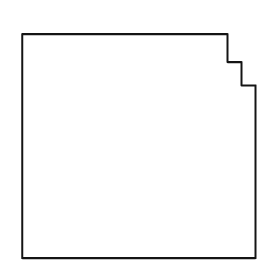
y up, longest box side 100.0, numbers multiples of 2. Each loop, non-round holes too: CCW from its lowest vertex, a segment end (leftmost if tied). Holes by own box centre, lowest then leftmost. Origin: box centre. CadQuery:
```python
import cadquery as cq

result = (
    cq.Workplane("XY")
    .moveTo(-50.0, -48.0)
    .lineTo(50.0, -48.0)
    .lineTo(50.0, 26.0)
    .lineTo(44.0, 26.0)
    .lineTo(44.0, 36.0)
    .lineTo(38.0, 36.0)
    .lineTo(38.0, 48.0)
    .lineTo(-50.0, 48.0)
    .close()
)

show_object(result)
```